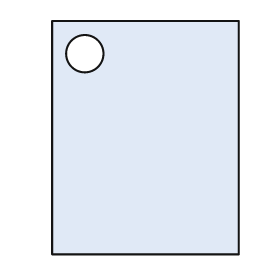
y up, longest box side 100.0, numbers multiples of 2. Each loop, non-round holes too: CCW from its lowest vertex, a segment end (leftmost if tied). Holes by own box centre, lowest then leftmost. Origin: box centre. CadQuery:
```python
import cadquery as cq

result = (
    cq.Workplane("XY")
    .moveTo(-40.0, -50.0)
    .lineTo(40.0, -50.0)
    .lineTo(40.0, 50.0)
    .lineTo(-40.0, 50.0)
    .close()
    .moveTo(-26.0, 36.0)
    .circle(8.0)
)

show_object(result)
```